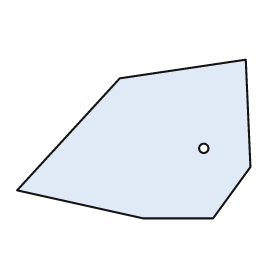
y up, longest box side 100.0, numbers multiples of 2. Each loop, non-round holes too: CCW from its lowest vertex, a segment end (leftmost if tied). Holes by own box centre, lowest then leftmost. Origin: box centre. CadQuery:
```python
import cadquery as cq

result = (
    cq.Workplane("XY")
    .moveTo(4.0, -34.0)
    .lineTo(34.0, -34.0)
    .lineTo(50.0, -12.0)
    .lineTo(48.0, 34.0)
    .lineTo(-6.0, 26.0)
    .lineTo(-50.0, -22.0)
    .close()
    .moveTo(30.0, -4.0)
    .circle(2.0)
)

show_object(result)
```